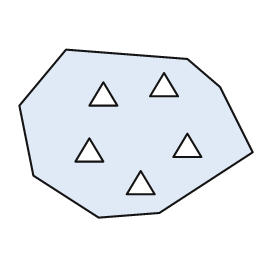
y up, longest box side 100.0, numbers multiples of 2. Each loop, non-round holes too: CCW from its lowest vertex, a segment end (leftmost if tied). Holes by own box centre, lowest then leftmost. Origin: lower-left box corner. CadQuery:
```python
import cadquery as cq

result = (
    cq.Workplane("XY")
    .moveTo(34.0, 0.0)
    .lineTo(60.0, 2.0)
    .lineTo(100.0, 28.0)
    .lineTo(86.0, 56.0)
    .lineTo(72.0, 68.0)
    .lineTo(20.0, 72.0)
    .lineTo(0.0, 48.0)
    .lineTo(6.0, 18.0)
    .close()
    .moveTo(46.0, 10.0)
    .lineTo(58.0, 10.0)
    .lineTo(52.0, 20.0)
    .close()
    .moveTo(24.0, 24.0)
    .lineTo(36.0, 24.0)
    .lineTo(30.0, 34.0)
    .close()
    .moveTo(66.0, 26.0)
    .lineTo(78.0, 26.0)
    .lineTo(72.0, 36.0)
    .close()
    .moveTo(30.0, 48.0)
    .lineTo(42.0, 48.0)
    .lineTo(36.0, 58.0)
    .close()
    .moveTo(56.0, 52.0)
    .lineTo(68.0, 52.0)
    .lineTo(62.0, 62.0)
    .close()
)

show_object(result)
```